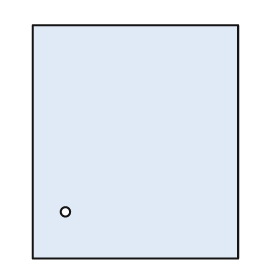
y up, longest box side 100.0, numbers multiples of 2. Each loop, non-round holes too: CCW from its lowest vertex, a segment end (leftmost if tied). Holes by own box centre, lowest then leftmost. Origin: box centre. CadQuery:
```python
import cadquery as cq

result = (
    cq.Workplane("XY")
    .moveTo(-44.0, -50.0)
    .lineTo(44.0, -50.0)
    .lineTo(44.0, 50.0)
    .lineTo(-44.0, 50.0)
    .close()
    .moveTo(-30.0, -30.0)
    .circle(2.0)
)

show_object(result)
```